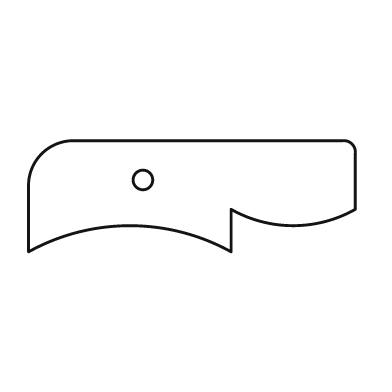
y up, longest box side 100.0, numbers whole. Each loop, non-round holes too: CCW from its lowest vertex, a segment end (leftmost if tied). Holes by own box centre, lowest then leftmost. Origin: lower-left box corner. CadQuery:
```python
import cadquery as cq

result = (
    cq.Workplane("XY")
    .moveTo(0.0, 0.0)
    .threePointArc((31.0, 8.0), (62.0, 0.0))
    .lineTo(62.0, 13.0)
    .threePointArc((81.0, 8.0), (100.0, 13.0))
    .lineTo(100.0, 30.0)
    .threePointArc((99.0, 33.0), (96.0, 34.0))
    .lineTo(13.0, 34.0)
    .threePointArc((4.0, 30.0), (0.0, 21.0))
    .close()
    .moveTo(35.0, 22.0)
    .circle(3.0)
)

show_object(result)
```